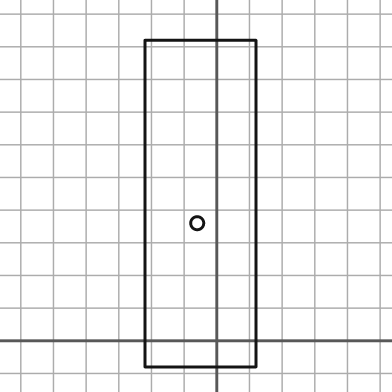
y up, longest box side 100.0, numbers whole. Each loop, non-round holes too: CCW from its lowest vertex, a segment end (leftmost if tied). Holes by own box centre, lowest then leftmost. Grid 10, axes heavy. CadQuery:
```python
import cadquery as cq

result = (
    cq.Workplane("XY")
    .moveTo(-22.0, -8.0)
    .lineTo(12.0, -8.0)
    .lineTo(12.0, 92.0)
    .lineTo(-22.0, 92.0)
    .close()
    .moveTo(-6.0, 36.0)
    .circle(2.0)
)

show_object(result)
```